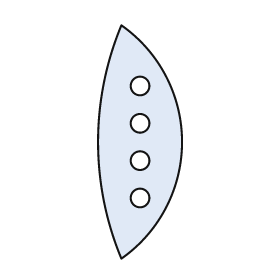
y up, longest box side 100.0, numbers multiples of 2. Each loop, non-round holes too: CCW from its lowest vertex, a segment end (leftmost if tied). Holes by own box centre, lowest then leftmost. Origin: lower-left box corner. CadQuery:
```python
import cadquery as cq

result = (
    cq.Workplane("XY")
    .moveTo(10.0, 0.0)
    .threePointArc((36.0, 50.0), (10.0, 100.0))
    .threePointArc((0.0, 50.0), (10.0, 0.0))
    .close()
    .moveTo(18.0, 26.0)
    .circle(4.0)
    .moveTo(18.0, 42.0)
    .circle(4.0)
    .moveTo(18.0, 58.0)
    .circle(4.0)
    .moveTo(18.0, 74.0)
    .circle(4.0)
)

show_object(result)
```